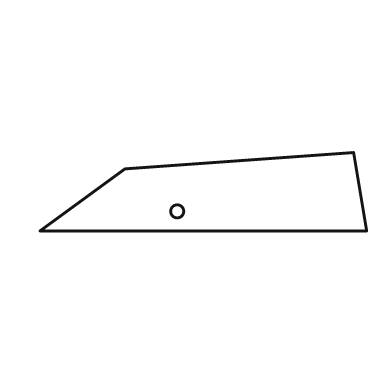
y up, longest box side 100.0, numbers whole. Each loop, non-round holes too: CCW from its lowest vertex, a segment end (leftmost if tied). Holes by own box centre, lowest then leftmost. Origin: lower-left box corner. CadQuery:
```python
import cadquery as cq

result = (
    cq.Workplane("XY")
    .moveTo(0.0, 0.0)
    .lineTo(100.0, 0.0)
    .lineTo(96.0, 24.0)
    .lineTo(26.0, 19.0)
    .close()
    .moveTo(42.0, 6.0)
    .circle(2.0)
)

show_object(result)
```